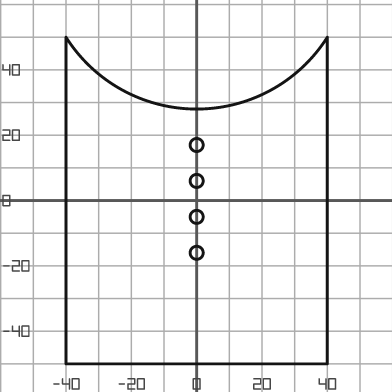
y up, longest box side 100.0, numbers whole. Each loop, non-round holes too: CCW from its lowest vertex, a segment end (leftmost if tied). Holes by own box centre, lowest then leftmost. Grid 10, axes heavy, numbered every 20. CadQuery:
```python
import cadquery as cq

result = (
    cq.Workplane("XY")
    .moveTo(-40.0, -50.0)
    .lineTo(40.0, -50.0)
    .lineTo(40.0, 50.0)
    .threePointArc((0.0, 28.0), (-40.0, 50.0))
    .close()
    .moveTo(0.0, -16.0)
    .circle(2.0)
    .moveTo(0.0, -5.0)
    .circle(2.0)
    .moveTo(0.0, 6.0)
    .circle(2.0)
    .moveTo(0.0, 17.0)
    .circle(2.0)
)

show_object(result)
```